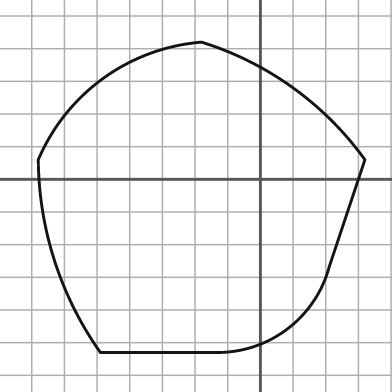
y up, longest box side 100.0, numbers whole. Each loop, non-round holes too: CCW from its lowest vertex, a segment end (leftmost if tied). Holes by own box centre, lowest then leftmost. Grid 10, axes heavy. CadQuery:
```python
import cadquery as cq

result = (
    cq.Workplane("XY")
    .moveTo(-49.0, -53.0)
    .lineTo(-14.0, -53.0)
    .threePointArc((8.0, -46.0), (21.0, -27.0))
    .lineTo(32.0, 6.0)
    .threePointArc((10.0, 28.0), (-18.0, 42.0))
    .threePointArc((-48.0, 31.0), (-68.0, 6.0))
    .threePointArc((-63.0, -25.0), (-49.0, -53.0))
    .close()
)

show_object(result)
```